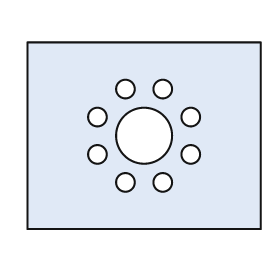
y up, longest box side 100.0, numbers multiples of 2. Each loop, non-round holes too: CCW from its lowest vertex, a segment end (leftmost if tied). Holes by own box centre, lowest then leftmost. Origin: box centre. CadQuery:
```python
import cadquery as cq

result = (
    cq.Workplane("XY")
    .moveTo(-50.0, -40.0)
    .lineTo(50.0, -40.0)
    .lineTo(50.0, 40.0)
    .lineTo(-50.0, 40.0)
    .close()
    .moveTo(-8.0, -20.0)
    .circle(4.0)
    .moveTo(8.0, -20.0)
    .circle(4.0)
    .moveTo(-20.0, -8.0)
    .circle(4.0)
    .moveTo(20.0, -8.0)
    .circle(4.0)
    .moveTo(0.0, 0.0)
    .circle(12.0)
    .moveTo(-20.0, 8.0)
    .circle(4.0)
    .moveTo(20.0, 8.0)
    .circle(4.0)
    .moveTo(-8.0, 20.0)
    .circle(4.0)
    .moveTo(8.0, 20.0)
    .circle(4.0)
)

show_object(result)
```